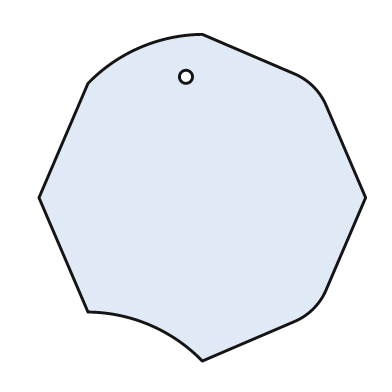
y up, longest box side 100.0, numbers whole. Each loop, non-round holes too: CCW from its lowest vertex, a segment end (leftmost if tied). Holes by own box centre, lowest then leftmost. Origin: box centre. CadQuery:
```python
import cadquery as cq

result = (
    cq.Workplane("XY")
    .moveTo(0.0, -50.0)
    .lineTo(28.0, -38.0)
    .threePointArc((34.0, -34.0), (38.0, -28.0))
    .lineTo(50.0, 0.0)
    .lineTo(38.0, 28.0)
    .threePointArc((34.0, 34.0), (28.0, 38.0))
    .lineTo(0.0, 50.0)
    .threePointArc((-19.0, 46.0), (-35.0, 35.0))
    .lineTo(-50.0, 0.0)
    .lineTo(-35.0, -35.0)
    .threePointArc((-16.0, -39.0), (0.0, -50.0))
    .close()
    .moveTo(-5.0, 37.0)
    .circle(2.0)
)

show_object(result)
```